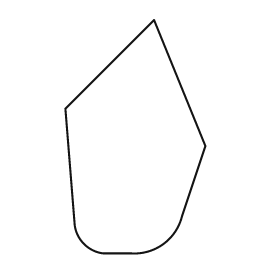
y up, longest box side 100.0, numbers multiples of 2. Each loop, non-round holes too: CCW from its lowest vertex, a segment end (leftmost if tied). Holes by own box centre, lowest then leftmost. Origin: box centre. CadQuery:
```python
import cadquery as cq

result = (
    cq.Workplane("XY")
    .moveTo(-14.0, -50.0)
    .lineTo(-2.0, -50.0)
    .threePointArc((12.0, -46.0), (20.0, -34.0))
    .lineTo(30.0, -4.0)
    .lineTo(8.0, 50.0)
    .lineTo(-30.0, 12.0)
    .lineTo(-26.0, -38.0)
    .threePointArc((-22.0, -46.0), (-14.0, -50.0))
    .close()
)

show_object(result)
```